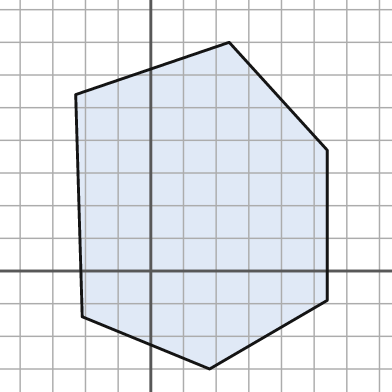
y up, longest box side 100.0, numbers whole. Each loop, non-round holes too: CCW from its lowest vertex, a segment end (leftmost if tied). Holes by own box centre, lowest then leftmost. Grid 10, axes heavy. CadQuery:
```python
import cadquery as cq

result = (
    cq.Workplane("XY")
    .moveTo(18.0, -30.0)
    .lineTo(54.0, -9.0)
    .lineTo(54.0, 37.0)
    .lineTo(24.0, 70.0)
    .lineTo(-23.0, 54.0)
    .lineTo(-21.0, -14.0)
    .close()
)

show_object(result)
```